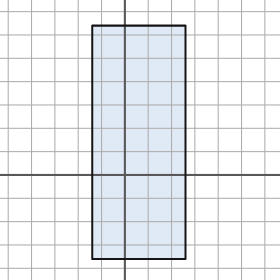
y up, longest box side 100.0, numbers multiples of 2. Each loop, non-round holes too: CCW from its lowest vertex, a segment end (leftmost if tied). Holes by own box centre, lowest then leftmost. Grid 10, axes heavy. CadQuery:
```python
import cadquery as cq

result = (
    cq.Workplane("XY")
    .moveTo(-14.0, -36.0)
    .lineTo(26.0, -36.0)
    .lineTo(26.0, 64.0)
    .lineTo(-14.0, 64.0)
    .close()
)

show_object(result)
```